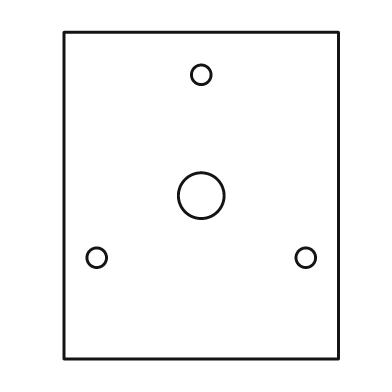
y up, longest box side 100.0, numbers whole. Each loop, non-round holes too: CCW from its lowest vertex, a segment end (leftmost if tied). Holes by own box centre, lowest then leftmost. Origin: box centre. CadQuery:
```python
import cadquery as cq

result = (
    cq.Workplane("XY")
    .moveTo(-42.0, -50.0)
    .lineTo(42.0, -50.0)
    .lineTo(42.0, 50.0)
    .lineTo(-42.0, 50.0)
    .close()
    .moveTo(-32.0, -19.0)
    .circle(3.0)
    .moveTo(32.0, -19.0)
    .circle(3.0)
    .moveTo(0.0, 0.0)
    .circle(7.0)
    .moveTo(0.0, 37.0)
    .circle(3.0)
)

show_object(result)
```